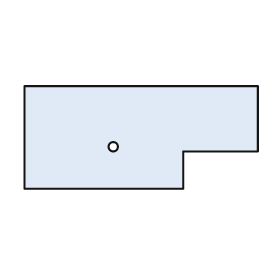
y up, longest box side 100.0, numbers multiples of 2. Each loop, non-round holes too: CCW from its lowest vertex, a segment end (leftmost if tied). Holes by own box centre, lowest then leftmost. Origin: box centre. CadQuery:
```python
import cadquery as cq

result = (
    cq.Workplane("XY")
    .moveTo(-50.0, -22.0)
    .lineTo(18.0, -22.0)
    .lineTo(18.0, -6.0)
    .lineTo(50.0, -6.0)
    .lineTo(50.0, 22.0)
    .lineTo(-50.0, 22.0)
    .close()
    .moveTo(-12.0, -4.0)
    .circle(2.0)
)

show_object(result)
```